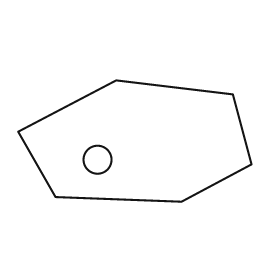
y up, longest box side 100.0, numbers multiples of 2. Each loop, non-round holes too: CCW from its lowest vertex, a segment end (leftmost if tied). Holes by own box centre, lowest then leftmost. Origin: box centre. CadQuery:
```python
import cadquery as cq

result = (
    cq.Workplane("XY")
    .moveTo(20.0, -26.0)
    .lineTo(50.0, -10.0)
    .lineTo(42.0, 20.0)
    .lineTo(-8.0, 26.0)
    .lineTo(-50.0, 4.0)
    .lineTo(-34.0, -24.0)
    .close()
    .moveTo(-16.0, -8.0)
    .circle(6.0)
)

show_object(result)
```